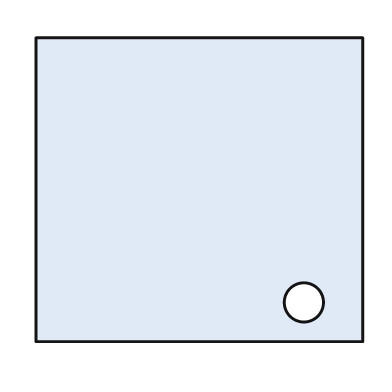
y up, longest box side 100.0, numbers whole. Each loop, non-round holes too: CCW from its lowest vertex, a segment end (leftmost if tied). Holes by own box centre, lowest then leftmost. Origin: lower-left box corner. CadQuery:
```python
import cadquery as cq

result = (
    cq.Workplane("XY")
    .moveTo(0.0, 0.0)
    .lineTo(100.0, 0.0)
    .lineTo(100.0, 93.0)
    .lineTo(0.0, 93.0)
    .close()
    .moveTo(82.0, 12.0)
    .circle(6.0)
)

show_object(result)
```